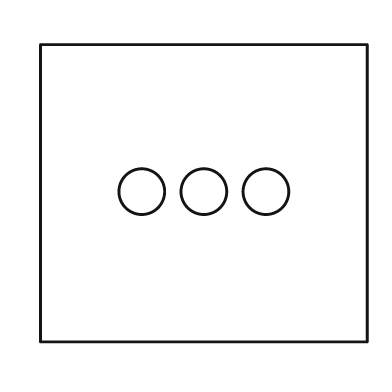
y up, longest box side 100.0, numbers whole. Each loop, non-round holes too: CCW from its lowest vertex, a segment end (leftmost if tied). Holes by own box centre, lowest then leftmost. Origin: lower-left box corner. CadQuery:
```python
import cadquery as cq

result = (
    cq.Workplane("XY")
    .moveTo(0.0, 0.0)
    .lineTo(100.0, 0.0)
    .lineTo(100.0, 91.0)
    .lineTo(0.0, 91.0)
    .close()
    .moveTo(31.0, 46.0)
    .circle(7.0)
    .moveTo(50.0, 46.0)
    .circle(7.0)
    .moveTo(69.0, 46.0)
    .circle(7.0)
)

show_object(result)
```